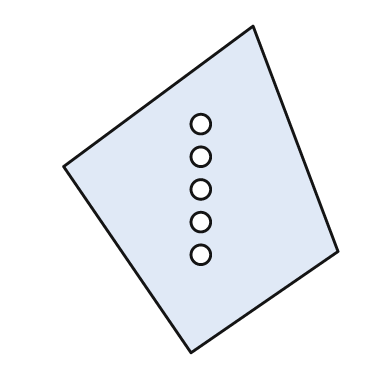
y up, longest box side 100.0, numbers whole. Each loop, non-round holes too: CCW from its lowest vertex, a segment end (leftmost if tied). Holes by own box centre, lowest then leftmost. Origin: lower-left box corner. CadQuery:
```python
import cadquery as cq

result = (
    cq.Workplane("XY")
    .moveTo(39.0, 0.0)
    .lineTo(84.0, 31.0)
    .lineTo(58.0, 100.0)
    .lineTo(0.0, 57.0)
    .close()
    .moveTo(42.0, 30.0)
    .circle(3.0)
    .moveTo(42.0, 40.0)
    .circle(3.0)
    .moveTo(42.0, 50.0)
    .circle(3.0)
    .moveTo(42.0, 60.0)
    .circle(3.0)
    .moveTo(42.0, 70.0)
    .circle(3.0)
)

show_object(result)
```